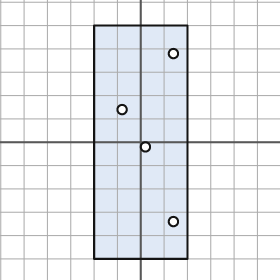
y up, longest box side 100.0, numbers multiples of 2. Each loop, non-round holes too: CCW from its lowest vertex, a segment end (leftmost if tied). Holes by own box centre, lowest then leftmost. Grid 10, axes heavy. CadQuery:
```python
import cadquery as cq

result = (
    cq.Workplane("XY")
    .moveTo(-20.0, -50.0)
    .lineTo(20.0, -50.0)
    .lineTo(20.0, 50.0)
    .lineTo(-20.0, 50.0)
    .close()
    .moveTo(14.0, -34.0)
    .circle(2.0)
    .moveTo(2.0, -2.0)
    .circle(2.0)
    .moveTo(-8.0, 14.0)
    .circle(2.0)
    .moveTo(14.0, 38.0)
    .circle(2.0)
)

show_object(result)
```